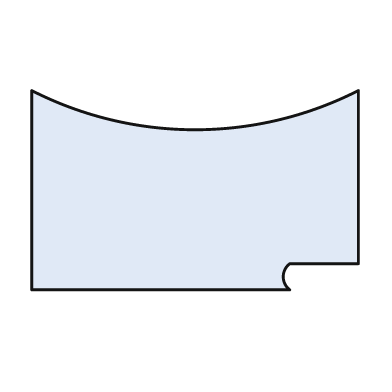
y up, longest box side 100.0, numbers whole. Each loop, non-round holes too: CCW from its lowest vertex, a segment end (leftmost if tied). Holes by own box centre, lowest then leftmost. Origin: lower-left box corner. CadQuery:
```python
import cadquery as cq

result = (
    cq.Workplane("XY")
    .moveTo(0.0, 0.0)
    .lineTo(79.0, 0.0)
    .threePointArc((77.0, 4.0), (79.0, 8.0))
    .lineTo(100.0, 8.0)
    .lineTo(100.0, 61.0)
    .threePointArc((50.0, 49.0), (0.0, 61.0))
    .close()
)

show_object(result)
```